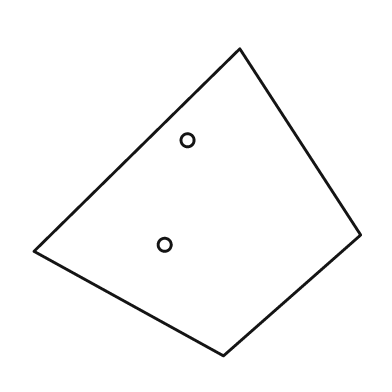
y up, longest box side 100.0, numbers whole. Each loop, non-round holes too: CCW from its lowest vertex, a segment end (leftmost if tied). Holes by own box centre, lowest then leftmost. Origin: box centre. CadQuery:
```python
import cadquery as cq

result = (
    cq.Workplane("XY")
    .moveTo(8.0, -47.0)
    .lineTo(50.0, -10.0)
    .lineTo(13.0, 47.0)
    .lineTo(-50.0, -15.0)
    .close()
    .moveTo(-10.0, -13.0)
    .circle(2.0)
    .moveTo(-3.0, 19.0)
    .circle(2.0)
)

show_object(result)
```